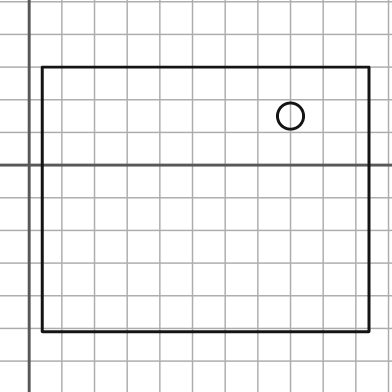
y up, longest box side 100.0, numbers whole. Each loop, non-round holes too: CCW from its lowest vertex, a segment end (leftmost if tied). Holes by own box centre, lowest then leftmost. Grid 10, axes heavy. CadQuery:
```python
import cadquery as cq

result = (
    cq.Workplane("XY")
    .moveTo(4.0, -51.0)
    .lineTo(104.0, -51.0)
    .lineTo(104.0, 30.0)
    .lineTo(4.0, 30.0)
    .close()
    .moveTo(80.0, 15.0)
    .circle(4.0)
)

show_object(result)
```